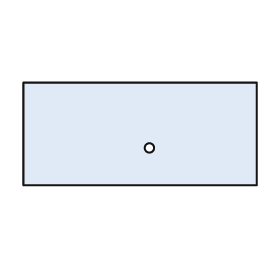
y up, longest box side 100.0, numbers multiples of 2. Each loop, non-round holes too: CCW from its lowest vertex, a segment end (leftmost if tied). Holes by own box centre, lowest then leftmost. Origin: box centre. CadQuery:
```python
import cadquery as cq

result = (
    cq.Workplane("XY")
    .moveTo(-50.0, -22.0)
    .lineTo(50.0, -22.0)
    .lineTo(50.0, 22.0)
    .lineTo(-50.0, 22.0)
    .close()
    .moveTo(4.0, -6.0)
    .circle(2.0)
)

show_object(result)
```